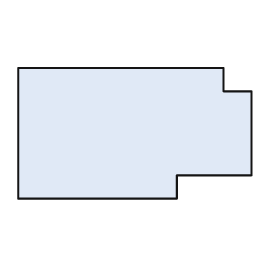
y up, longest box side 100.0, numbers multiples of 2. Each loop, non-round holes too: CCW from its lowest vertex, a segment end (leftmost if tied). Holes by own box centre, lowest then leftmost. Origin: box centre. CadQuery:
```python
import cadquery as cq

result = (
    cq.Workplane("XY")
    .moveTo(-50.0, -28.0)
    .lineTo(18.0, -28.0)
    .lineTo(18.0, -18.0)
    .lineTo(50.0, -18.0)
    .lineTo(50.0, 18.0)
    .lineTo(38.0, 18.0)
    .lineTo(38.0, 28.0)
    .lineTo(-50.0, 28.0)
    .close()
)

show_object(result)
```